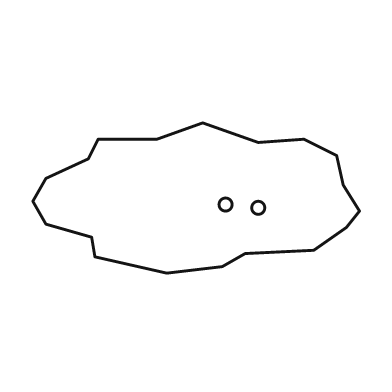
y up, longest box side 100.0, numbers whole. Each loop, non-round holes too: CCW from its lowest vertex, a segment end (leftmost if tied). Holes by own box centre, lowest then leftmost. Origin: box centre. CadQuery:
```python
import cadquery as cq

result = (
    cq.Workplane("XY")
    .moveTo(-9.0, -23.0)
    .lineTo(8.0, -21.0)
    .lineTo(15.0, -17.0)
    .lineTo(36.0, -16.0)
    .lineTo(46.0, -9.0)
    .lineTo(50.0, -4.0)
    .lineTo(45.0, 4.0)
    .lineTo(43.0, 13.0)
    .lineTo(33.0, 18.0)
    .lineTo(19.0, 17.0)
    .lineTo(2.0, 23.0)
    .lineTo(-12.0, 18.0)
    .lineTo(-30.0, 18.0)
    .lineTo(-33.0, 12.0)
    .lineTo(-46.0, 6.0)
    .lineTo(-50.0, -1.0)
    .lineTo(-46.0, -8.0)
    .lineTo(-32.0, -12.0)
    .lineTo(-31.0, -18.0)
    .close()
    .moveTo(19.0, -3.0)
    .circle(2.0)
    .moveTo(9.0, -2.0)
    .circle(2.0)
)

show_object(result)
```